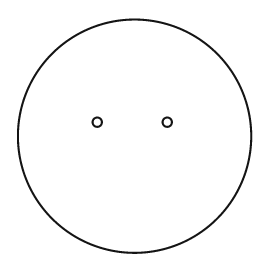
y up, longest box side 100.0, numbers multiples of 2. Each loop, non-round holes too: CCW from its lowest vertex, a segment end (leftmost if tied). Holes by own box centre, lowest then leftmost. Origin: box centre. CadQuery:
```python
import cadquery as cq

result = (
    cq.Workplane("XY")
    .moveTo(0.0, 0.0)
    .circle(50.0)
    .moveTo(-16.0, 6.0)
    .circle(2.0)
    .moveTo(14.0, 6.0)
    .circle(2.0)
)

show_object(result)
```